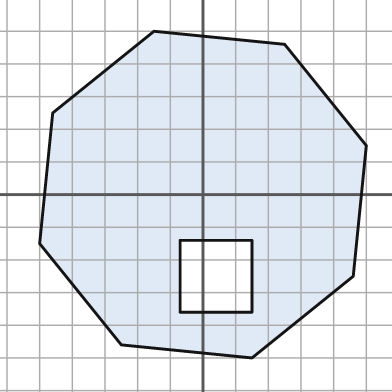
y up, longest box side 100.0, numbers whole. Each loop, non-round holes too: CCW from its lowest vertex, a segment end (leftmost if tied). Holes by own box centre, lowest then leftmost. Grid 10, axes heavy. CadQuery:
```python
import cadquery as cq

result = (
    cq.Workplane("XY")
    .moveTo(15.0, -50.0)
    .lineTo(46.0, -25.0)
    .lineTo(50.0, 15.0)
    .lineTo(25.0, 46.0)
    .lineTo(-15.0, 50.0)
    .lineTo(-46.0, 25.0)
    .lineTo(-50.0, -15.0)
    .lineTo(-25.0, -46.0)
    .close()
    .moveTo(-7.0, -36.0)
    .lineTo(15.0, -36.0)
    .lineTo(15.0, -14.0)
    .lineTo(-7.0, -14.0)
    .close()
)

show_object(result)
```